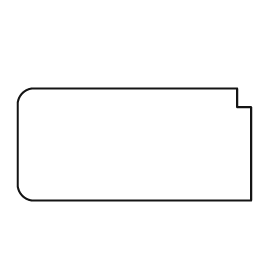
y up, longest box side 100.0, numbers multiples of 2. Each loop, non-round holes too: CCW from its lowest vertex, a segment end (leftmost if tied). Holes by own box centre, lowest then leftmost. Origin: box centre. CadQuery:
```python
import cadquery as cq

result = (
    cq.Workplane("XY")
    .moveTo(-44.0, -24.0)
    .lineTo(50.0, -24.0)
    .lineTo(50.0, 16.0)
    .lineTo(44.0, 16.0)
    .lineTo(44.0, 24.0)
    .lineTo(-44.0, 24.0)
    .threePointArc((-48.0, 22.0), (-50.0, 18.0))
    .lineTo(-50.0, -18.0)
    .threePointArc((-48.0, -22.0), (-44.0, -24.0))
    .close()
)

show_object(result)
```